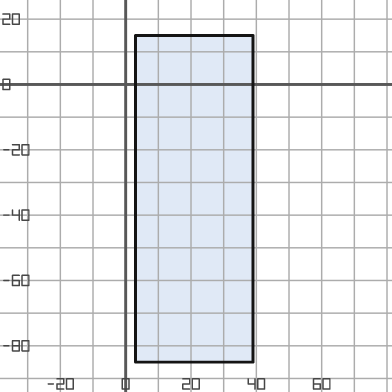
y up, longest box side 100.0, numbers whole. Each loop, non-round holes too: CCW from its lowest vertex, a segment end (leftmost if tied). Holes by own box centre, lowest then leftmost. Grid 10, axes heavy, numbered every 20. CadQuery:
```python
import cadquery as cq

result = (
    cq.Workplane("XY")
    .moveTo(3.0, -85.0)
    .lineTo(39.0, -85.0)
    .lineTo(39.0, 15.0)
    .lineTo(3.0, 15.0)
    .close()
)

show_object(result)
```